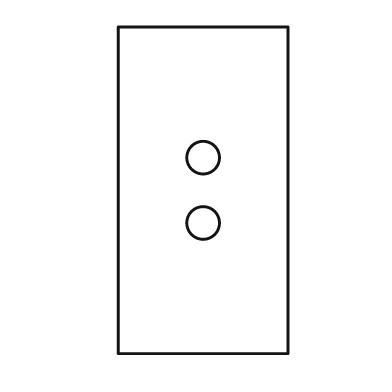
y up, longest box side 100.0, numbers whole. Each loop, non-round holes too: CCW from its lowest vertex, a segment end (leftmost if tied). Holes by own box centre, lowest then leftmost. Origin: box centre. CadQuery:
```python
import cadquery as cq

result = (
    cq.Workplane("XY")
    .moveTo(-26.0, -50.0)
    .lineTo(26.0, -50.0)
    .lineTo(26.0, 50.0)
    .lineTo(-26.0, 50.0)
    .close()
    .moveTo(0.0, -10.0)
    .circle(5.0)
    .moveTo(0.0, 10.0)
    .circle(5.0)
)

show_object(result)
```